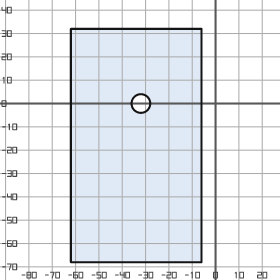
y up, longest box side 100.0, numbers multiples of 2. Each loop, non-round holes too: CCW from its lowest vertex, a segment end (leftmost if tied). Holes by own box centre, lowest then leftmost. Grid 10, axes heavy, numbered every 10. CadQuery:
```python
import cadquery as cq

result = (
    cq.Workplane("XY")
    .moveTo(-62.0, -68.0)
    .lineTo(-6.0, -68.0)
    .lineTo(-6.0, 32.0)
    .lineTo(-62.0, 32.0)
    .close()
    .moveTo(-32.0, 0.0)
    .circle(4.0)
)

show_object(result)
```